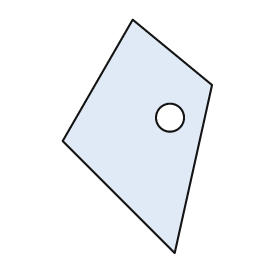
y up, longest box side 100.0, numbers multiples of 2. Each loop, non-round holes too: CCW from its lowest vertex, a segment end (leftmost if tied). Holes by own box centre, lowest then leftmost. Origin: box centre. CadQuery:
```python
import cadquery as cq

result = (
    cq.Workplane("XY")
    .moveTo(16.0, -50.0)
    .lineTo(32.0, 22.0)
    .lineTo(-2.0, 50.0)
    .lineTo(-32.0, -2.0)
    .close()
    .moveTo(14.0, 8.0)
    .circle(6.0)
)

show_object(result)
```